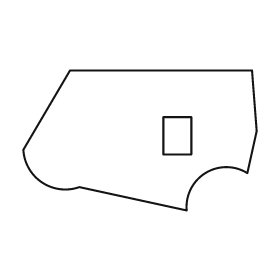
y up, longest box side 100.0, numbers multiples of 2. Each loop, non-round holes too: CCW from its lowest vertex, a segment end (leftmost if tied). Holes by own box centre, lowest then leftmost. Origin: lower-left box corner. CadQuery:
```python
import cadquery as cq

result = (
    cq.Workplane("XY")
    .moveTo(70.0, 0.0)
    .threePointArc((78.0, 16.0), (96.0, 16.0))
    .lineTo(100.0, 34.0)
    .lineTo(98.0, 60.0)
    .lineTo(20.0, 60.0)
    .lineTo(0.0, 26.0)
    .threePointArc((8.0, 12.0), (24.0, 10.0))
    .close()
    .moveTo(60.0, 24.0)
    .lineTo(72.0, 24.0)
    .lineTo(72.0, 40.0)
    .lineTo(60.0, 40.0)
    .close()
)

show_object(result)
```